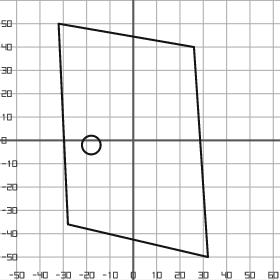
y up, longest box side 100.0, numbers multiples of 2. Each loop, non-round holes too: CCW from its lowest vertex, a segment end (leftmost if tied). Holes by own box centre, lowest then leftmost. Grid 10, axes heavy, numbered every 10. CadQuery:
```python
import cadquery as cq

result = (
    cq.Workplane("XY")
    .moveTo(32.0, -50.0)
    .lineTo(26.0, 40.0)
    .lineTo(-32.0, 50.0)
    .lineTo(-28.0, -36.0)
    .close()
    .moveTo(-18.0, -2.0)
    .circle(4.0)
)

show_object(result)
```